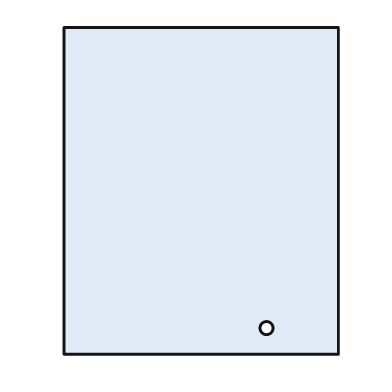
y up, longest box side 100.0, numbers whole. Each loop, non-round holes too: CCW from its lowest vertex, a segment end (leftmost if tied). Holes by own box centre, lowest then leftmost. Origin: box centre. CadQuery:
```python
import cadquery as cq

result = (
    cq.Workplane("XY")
    .moveTo(-42.0, -50.0)
    .lineTo(42.0, -50.0)
    .lineTo(42.0, 50.0)
    .lineTo(-42.0, 50.0)
    .close()
    .moveTo(20.0, -42.0)
    .circle(2.0)
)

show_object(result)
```